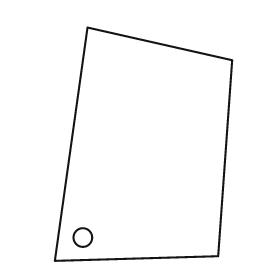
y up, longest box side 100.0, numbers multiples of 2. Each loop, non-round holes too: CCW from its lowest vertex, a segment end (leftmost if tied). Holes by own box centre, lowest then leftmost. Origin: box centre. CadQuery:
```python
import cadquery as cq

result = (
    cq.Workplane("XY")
    .moveTo(-38.0, -50.0)
    .lineTo(32.0, -48.0)
    .lineTo(38.0, 36.0)
    .lineTo(-24.0, 50.0)
    .close()
    .moveTo(-26.0, -40.0)
    .circle(4.0)
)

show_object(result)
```